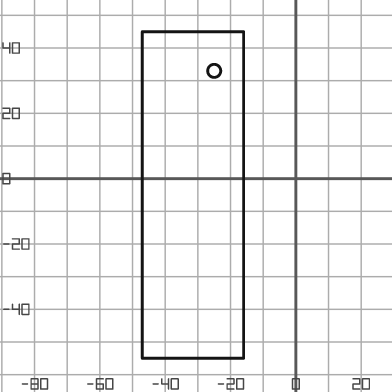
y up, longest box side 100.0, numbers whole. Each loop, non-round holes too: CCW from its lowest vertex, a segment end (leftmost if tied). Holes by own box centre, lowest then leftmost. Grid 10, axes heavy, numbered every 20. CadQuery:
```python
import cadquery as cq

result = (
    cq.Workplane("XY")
    .moveTo(-47.0, -55.0)
    .lineTo(-16.0, -55.0)
    .lineTo(-16.0, 45.0)
    .lineTo(-47.0, 45.0)
    .close()
    .moveTo(-25.0, 33.0)
    .circle(2.0)
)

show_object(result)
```